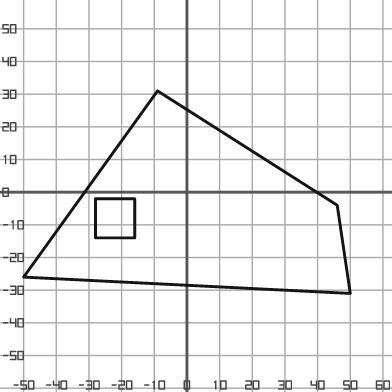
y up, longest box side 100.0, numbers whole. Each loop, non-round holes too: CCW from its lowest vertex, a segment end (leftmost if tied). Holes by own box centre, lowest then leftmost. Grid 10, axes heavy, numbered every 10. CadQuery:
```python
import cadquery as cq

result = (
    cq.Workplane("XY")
    .moveTo(50.0, -31.0)
    .lineTo(46.0, -4.0)
    .lineTo(-9.0, 31.0)
    .lineTo(-50.0, -26.0)
    .close()
    .moveTo(-28.0, -14.0)
    .lineTo(-16.0, -14.0)
    .lineTo(-16.0, -2.0)
    .lineTo(-28.0, -2.0)
    .close()
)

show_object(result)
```